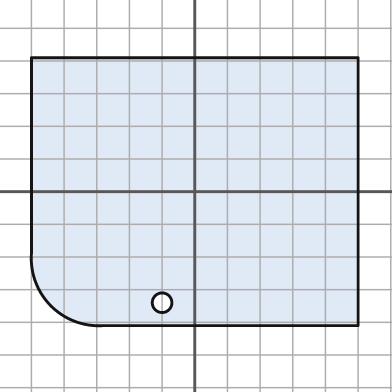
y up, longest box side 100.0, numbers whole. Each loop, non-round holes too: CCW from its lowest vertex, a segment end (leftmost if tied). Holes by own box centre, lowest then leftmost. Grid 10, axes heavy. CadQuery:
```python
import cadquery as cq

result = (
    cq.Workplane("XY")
    .moveTo(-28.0, -41.0)
    .lineTo(50.0, -41.0)
    .lineTo(50.0, 41.0)
    .lineTo(-50.0, 41.0)
    .lineTo(-50.0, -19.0)
    .threePointArc((-44.0, -35.0), (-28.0, -41.0))
    .close()
    .moveTo(-10.0, -34.0)
    .circle(3.0)
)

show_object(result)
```